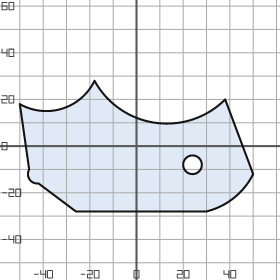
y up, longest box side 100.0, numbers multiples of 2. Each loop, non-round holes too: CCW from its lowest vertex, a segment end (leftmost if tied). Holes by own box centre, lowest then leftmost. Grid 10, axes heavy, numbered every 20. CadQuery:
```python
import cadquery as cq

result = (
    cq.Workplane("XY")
    .moveTo(-26.0, -28.0)
    .lineTo(30.0, -28.0)
    .threePointArc((42.0, -22.0), (50.0, -12.0))
    .lineTo(38.0, 20.0)
    .threePointArc((8.0, 10.0), (-18.0, 28.0))
    .threePointArc((-32.0, 16.0), (-50.0, 18.0))
    .lineTo(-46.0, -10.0)
    .threePointArc((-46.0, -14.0), (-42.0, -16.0))
    .close()
    .moveTo(24.0, -8.0)
    .circle(4.0)
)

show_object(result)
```